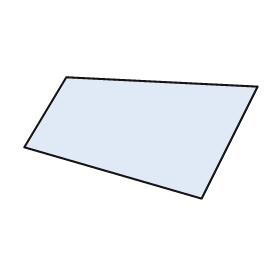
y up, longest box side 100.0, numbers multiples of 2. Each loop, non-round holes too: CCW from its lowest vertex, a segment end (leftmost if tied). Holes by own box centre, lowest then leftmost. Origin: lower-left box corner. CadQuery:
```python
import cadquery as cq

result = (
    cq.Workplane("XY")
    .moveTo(76.0, 0.0)
    .lineTo(100.0, 48.0)
    .lineTo(18.0, 52.0)
    .lineTo(0.0, 22.0)
    .close()
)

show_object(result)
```